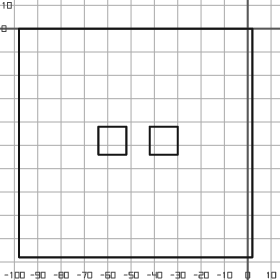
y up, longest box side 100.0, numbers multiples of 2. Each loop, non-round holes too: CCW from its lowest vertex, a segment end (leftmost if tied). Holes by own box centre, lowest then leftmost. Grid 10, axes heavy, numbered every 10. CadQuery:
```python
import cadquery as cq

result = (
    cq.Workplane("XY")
    .moveTo(-98.0, -98.0)
    .lineTo(2.0, -98.0)
    .lineTo(2.0, 0.0)
    .lineTo(-98.0, 0.0)
    .close()
    .moveTo(-64.0, -54.0)
    .lineTo(-52.0, -54.0)
    .lineTo(-52.0, -42.0)
    .lineTo(-64.0, -42.0)
    .close()
    .moveTo(-42.0, -54.0)
    .lineTo(-30.0, -54.0)
    .lineTo(-30.0, -42.0)
    .lineTo(-42.0, -42.0)
    .close()
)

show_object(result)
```